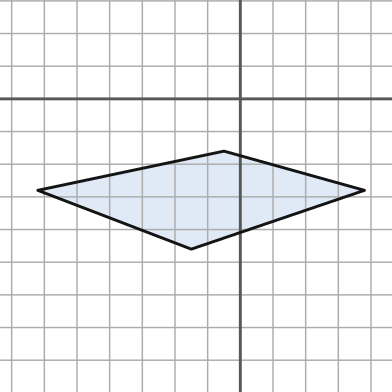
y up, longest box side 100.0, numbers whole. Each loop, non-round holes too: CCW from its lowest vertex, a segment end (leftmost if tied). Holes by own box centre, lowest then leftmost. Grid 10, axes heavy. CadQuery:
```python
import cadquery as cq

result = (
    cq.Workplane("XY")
    .moveTo(-15.0, -46.0)
    .lineTo(38.0, -28.0)
    .lineTo(-5.0, -16.0)
    .lineTo(-62.0, -28.0)
    .close()
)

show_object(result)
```